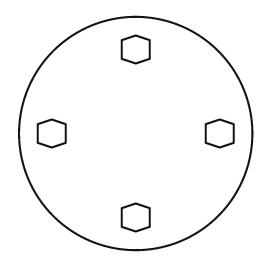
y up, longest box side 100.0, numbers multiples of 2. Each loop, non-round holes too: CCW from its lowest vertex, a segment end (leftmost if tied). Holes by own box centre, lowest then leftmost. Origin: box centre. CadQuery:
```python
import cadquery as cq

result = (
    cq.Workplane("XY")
    .moveTo(0.0, 0.0)
    .circle(50.0)
    .moveTo(0.0, -42.0)
    .lineTo(6.0, -40.0)
    .lineTo(6.0, -32.0)
    .lineTo(0.0, -30.0)
    .lineTo(-6.0, -32.0)
    .lineTo(-6.0, -40.0)
    .close()
    .moveTo(-36.0, -6.0)
    .lineTo(-30.0, -4.0)
    .lineTo(-30.0, 4.0)
    .lineTo(-36.0, 6.0)
    .lineTo(-42.0, 4.0)
    .lineTo(-42.0, -4.0)
    .close()
    .moveTo(36.0, -6.0)
    .lineTo(42.0, -4.0)
    .lineTo(42.0, 4.0)
    .lineTo(36.0, 6.0)
    .lineTo(30.0, 4.0)
    .lineTo(30.0, -4.0)
    .close()
    .moveTo(0.0, 30.0)
    .lineTo(6.0, 32.0)
    .lineTo(6.0, 40.0)
    .lineTo(0.0, 42.0)
    .lineTo(-6.0, 40.0)
    .lineTo(-6.0, 32.0)
    .close()
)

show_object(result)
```